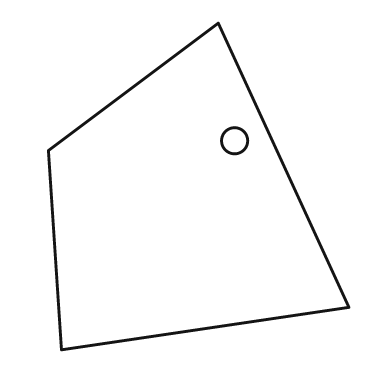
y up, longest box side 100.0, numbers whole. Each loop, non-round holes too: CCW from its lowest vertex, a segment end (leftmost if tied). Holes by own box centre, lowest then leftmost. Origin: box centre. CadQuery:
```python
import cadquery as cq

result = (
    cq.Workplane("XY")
    .moveTo(-42.0, -50.0)
    .lineTo(46.0, -37.0)
    .lineTo(6.0, 50.0)
    .lineTo(-46.0, 11.0)
    .close()
    .moveTo(11.0, 14.0)
    .circle(4.0)
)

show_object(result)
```